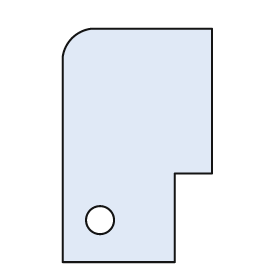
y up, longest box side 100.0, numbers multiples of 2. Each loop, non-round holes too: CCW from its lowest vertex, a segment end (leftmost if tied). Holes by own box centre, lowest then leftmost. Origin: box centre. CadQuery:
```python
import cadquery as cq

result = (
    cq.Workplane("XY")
    .moveTo(-32.0, -50.0)
    .lineTo(16.0, -50.0)
    .lineTo(16.0, -12.0)
    .lineTo(32.0, -12.0)
    .lineTo(32.0, 50.0)
    .lineTo(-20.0, 50.0)
    .threePointArc((-28.0, 46.0), (-32.0, 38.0))
    .close()
    .moveTo(-16.0, -32.0)
    .circle(6.0)
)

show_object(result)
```